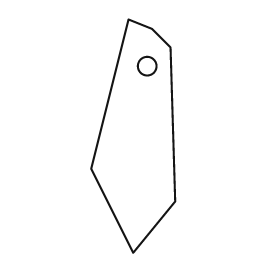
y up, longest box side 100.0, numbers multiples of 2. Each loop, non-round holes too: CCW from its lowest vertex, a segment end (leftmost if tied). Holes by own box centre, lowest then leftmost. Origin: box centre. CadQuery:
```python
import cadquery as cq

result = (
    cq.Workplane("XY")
    .moveTo(0.0, -50.0)
    .lineTo(18.0, -28.0)
    .lineTo(16.0, 38.0)
    .lineTo(8.0, 46.0)
    .lineTo(-2.0, 50.0)
    .lineTo(-18.0, -14.0)
    .close()
    .moveTo(6.0, 30.0)
    .circle(4.0)
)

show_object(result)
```